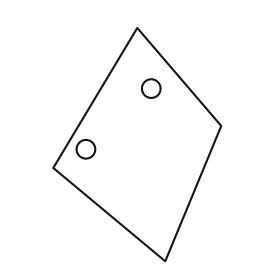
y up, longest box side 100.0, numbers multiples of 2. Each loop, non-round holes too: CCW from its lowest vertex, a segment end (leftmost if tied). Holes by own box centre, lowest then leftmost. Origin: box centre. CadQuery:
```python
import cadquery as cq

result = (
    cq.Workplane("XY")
    .moveTo(12.0, -50.0)
    .lineTo(36.0, 8.0)
    .lineTo(0.0, 50.0)
    .lineTo(-36.0, -10.0)
    .close()
    .moveTo(-22.0, -2.0)
    .circle(4.0)
    .moveTo(6.0, 24.0)
    .circle(4.0)
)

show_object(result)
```